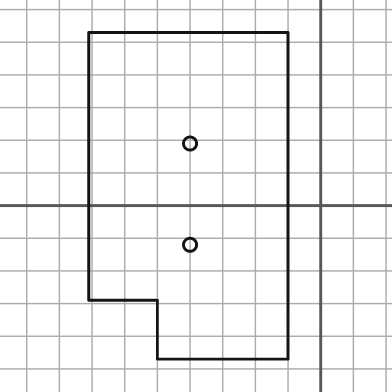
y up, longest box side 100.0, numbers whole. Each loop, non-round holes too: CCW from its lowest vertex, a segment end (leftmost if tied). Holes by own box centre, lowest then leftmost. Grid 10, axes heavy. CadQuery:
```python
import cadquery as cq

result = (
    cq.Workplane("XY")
    .moveTo(-50.0, -47.0)
    .lineTo(-10.0, -47.0)
    .lineTo(-10.0, 53.0)
    .lineTo(-71.0, 53.0)
    .lineTo(-71.0, -29.0)
    .lineTo(-50.0, -29.0)
    .close()
    .moveTo(-40.0, -12.0)
    .circle(2.0)
    .moveTo(-40.0, 19.0)
    .circle(2.0)
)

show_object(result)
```